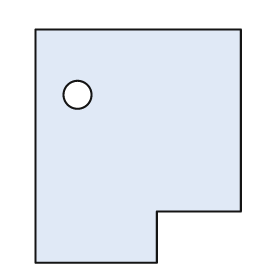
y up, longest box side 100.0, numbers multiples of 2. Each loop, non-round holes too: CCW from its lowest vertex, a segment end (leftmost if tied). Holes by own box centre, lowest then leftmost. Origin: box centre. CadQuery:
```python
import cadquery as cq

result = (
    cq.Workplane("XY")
    .moveTo(-44.0, -50.0)
    .lineTo(8.0, -50.0)
    .lineTo(8.0, -28.0)
    .lineTo(44.0, -28.0)
    .lineTo(44.0, 50.0)
    .lineTo(-44.0, 50.0)
    .close()
    .moveTo(-26.0, 22.0)
    .circle(6.0)
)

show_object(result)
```